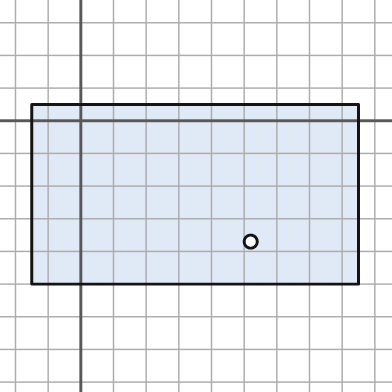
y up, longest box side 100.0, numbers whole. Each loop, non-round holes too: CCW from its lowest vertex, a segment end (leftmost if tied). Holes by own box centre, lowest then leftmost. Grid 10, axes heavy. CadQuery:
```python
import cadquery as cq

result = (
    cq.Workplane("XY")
    .moveTo(-15.0, -50.0)
    .lineTo(85.0, -50.0)
    .lineTo(85.0, 5.0)
    .lineTo(-15.0, 5.0)
    .close()
    .moveTo(52.0, -37.0)
    .circle(2.0)
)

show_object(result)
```